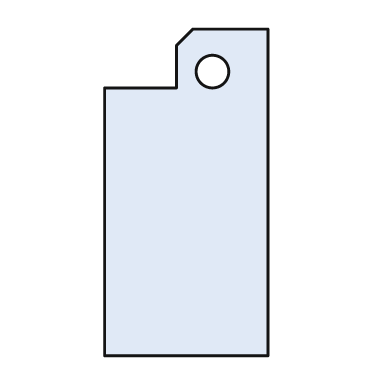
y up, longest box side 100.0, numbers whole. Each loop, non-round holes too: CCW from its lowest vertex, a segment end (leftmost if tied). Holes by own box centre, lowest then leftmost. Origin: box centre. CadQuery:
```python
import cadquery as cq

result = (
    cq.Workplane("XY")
    .moveTo(-25.0, -50.0)
    .lineTo(25.0, -50.0)
    .lineTo(25.0, 50.0)
    .lineTo(2.0, 50.0)
    .lineTo(-3.0, 45.0)
    .lineTo(-3.0, 32.0)
    .lineTo(-25.0, 32.0)
    .close()
    .moveTo(8.0, 37.0)
    .circle(5.0)
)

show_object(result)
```